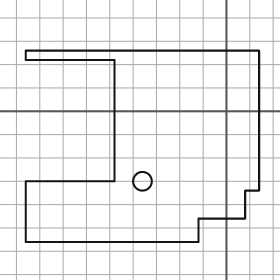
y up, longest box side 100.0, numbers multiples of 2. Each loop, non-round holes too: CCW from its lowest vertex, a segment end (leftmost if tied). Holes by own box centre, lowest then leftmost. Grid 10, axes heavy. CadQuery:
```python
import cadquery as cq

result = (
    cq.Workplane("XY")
    .moveTo(-86.0, -56.0)
    .lineTo(-12.0, -56.0)
    .lineTo(-12.0, -46.0)
    .lineTo(8.0, -46.0)
    .lineTo(8.0, -34.0)
    .lineTo(14.0, -34.0)
    .lineTo(14.0, 26.0)
    .lineTo(-86.0, 26.0)
    .lineTo(-86.0, 22.0)
    .lineTo(-48.0, 22.0)
    .lineTo(-48.0, -30.0)
    .lineTo(-86.0, -30.0)
    .close()
    .moveTo(-36.0, -30.0)
    .circle(4.0)
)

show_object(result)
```